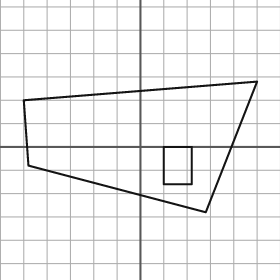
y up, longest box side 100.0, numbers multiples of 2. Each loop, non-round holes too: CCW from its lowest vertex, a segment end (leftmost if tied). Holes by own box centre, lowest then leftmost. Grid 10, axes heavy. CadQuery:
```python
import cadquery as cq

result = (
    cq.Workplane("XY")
    .moveTo(28.0, -28.0)
    .lineTo(50.0, 28.0)
    .lineTo(-50.0, 20.0)
    .lineTo(-48.0, -8.0)
    .close()
    .moveTo(10.0, -16.0)
    .lineTo(22.0, -16.0)
    .lineTo(22.0, 0.0)
    .lineTo(10.0, 0.0)
    .close()
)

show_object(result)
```